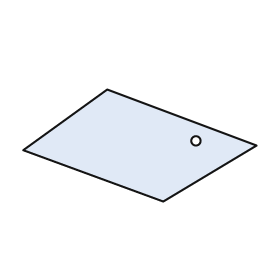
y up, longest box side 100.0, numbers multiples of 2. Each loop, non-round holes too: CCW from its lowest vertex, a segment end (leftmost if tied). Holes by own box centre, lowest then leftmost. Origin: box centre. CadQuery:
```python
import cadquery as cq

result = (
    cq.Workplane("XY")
    .moveTo(10.0, -24.0)
    .lineTo(50.0, 0.0)
    .lineTo(-14.0, 24.0)
    .lineTo(-50.0, -2.0)
    .close()
    .moveTo(24.0, 2.0)
    .circle(2.0)
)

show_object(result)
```